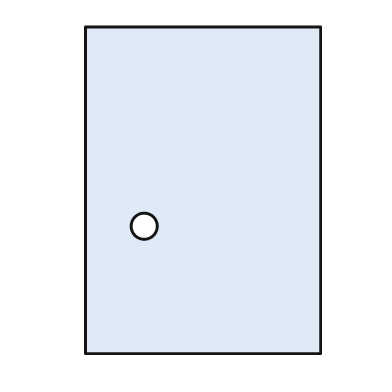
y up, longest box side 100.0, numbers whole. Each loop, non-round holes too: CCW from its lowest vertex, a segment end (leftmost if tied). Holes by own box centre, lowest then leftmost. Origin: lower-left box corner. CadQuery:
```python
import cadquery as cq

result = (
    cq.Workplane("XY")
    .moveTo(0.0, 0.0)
    .lineTo(72.0, 0.0)
    .lineTo(72.0, 100.0)
    .lineTo(0.0, 100.0)
    .close()
    .moveTo(18.0, 39.0)
    .circle(4.0)
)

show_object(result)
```